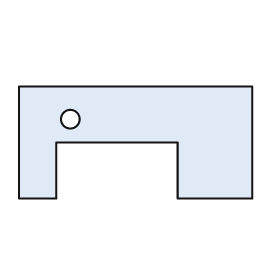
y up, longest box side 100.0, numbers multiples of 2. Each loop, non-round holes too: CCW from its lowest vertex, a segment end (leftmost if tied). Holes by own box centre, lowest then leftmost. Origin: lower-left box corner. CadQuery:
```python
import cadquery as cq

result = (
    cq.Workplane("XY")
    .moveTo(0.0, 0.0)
    .lineTo(16.0, 0.0)
    .lineTo(16.0, 24.0)
    .lineTo(68.0, 24.0)
    .lineTo(68.0, 0.0)
    .lineTo(100.0, 0.0)
    .lineTo(100.0, 48.0)
    .lineTo(0.0, 48.0)
    .close()
    .moveTo(22.0, 34.0)
    .circle(4.0)
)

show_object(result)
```